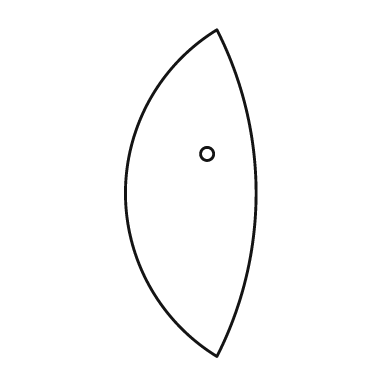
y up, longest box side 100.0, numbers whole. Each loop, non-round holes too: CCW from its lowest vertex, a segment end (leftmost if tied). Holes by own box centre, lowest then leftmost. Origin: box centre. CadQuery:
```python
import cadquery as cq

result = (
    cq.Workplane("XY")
    .moveTo(8.0, -50.0)
    .threePointArc((20.0, 0.0), (8.0, 50.0))
    .threePointArc((-20.0, 0.0), (8.0, -50.0))
    .close()
    .moveTo(5.0, 12.0)
    .circle(2.0)
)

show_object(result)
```